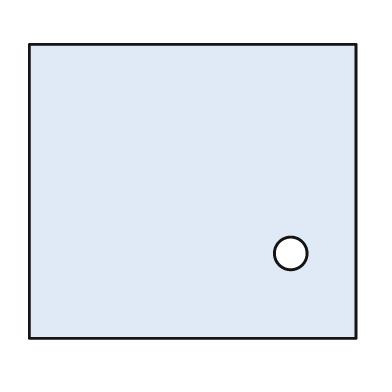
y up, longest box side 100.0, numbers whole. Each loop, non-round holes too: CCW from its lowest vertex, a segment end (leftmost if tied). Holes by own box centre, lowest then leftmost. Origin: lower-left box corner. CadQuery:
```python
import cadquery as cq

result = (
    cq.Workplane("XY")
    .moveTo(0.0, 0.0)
    .lineTo(100.0, 0.0)
    .lineTo(100.0, 90.0)
    .lineTo(0.0, 90.0)
    .close()
    .moveTo(80.0, 26.0)
    .circle(5.0)
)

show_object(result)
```